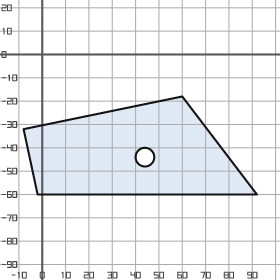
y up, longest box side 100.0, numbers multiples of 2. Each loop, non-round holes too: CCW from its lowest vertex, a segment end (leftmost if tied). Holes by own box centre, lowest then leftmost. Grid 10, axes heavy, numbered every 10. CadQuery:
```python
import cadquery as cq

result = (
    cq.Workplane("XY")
    .moveTo(-2.0, -60.0)
    .lineTo(92.0, -60.0)
    .lineTo(60.0, -18.0)
    .lineTo(-8.0, -32.0)
    .close()
    .moveTo(44.0, -44.0)
    .circle(4.0)
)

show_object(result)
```